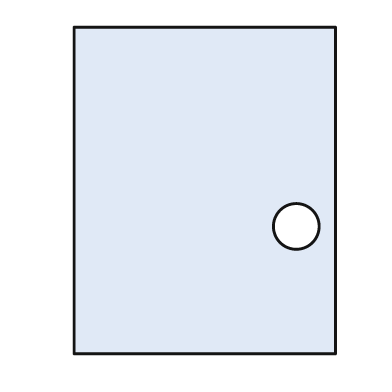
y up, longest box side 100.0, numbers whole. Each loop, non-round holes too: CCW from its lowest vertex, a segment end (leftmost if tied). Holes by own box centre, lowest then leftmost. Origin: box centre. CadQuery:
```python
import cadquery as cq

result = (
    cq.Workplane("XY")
    .moveTo(-40.0, -50.0)
    .lineTo(40.0, -50.0)
    .lineTo(40.0, 50.0)
    .lineTo(-40.0, 50.0)
    .close()
    .moveTo(28.0, -11.0)
    .circle(7.0)
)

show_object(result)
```